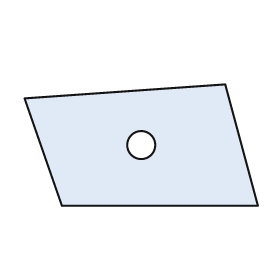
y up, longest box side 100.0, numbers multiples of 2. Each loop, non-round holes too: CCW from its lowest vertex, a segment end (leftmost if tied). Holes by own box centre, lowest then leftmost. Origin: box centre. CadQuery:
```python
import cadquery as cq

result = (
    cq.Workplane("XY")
    .moveTo(-34.0, -26.0)
    .lineTo(50.0, -26.0)
    .lineTo(36.0, 26.0)
    .lineTo(-50.0, 20.0)
    .close()
    .moveTo(0.0, 0.0)
    .circle(6.0)
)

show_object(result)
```